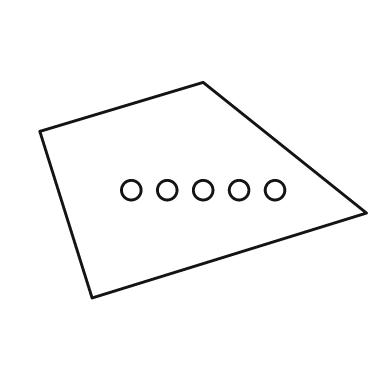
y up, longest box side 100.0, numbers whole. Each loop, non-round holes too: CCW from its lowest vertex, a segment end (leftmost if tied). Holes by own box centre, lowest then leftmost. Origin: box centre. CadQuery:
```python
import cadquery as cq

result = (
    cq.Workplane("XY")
    .moveTo(-34.0, -33.0)
    .lineTo(50.0, -7.0)
    .lineTo(0.0, 33.0)
    .lineTo(-50.0, 18.0)
    .close()
    .moveTo(-22.0, 0.0)
    .circle(3.0)
    .moveTo(-11.0, 0.0)
    .circle(3.0)
    .moveTo(0.0, 0.0)
    .circle(3.0)
    .moveTo(11.0, 0.0)
    .circle(3.0)
    .moveTo(22.0, 0.0)
    .circle(3.0)
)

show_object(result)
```